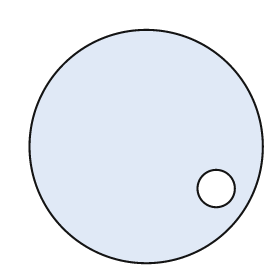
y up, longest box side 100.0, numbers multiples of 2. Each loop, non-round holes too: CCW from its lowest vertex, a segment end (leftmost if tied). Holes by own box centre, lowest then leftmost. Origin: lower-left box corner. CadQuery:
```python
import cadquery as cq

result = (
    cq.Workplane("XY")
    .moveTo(50.0, 50.0)
    .circle(50.0)
    .moveTo(80.0, 32.0)
    .circle(8.0)
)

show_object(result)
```